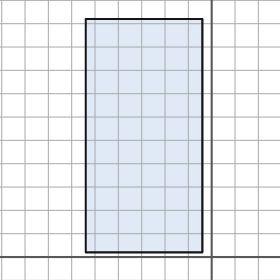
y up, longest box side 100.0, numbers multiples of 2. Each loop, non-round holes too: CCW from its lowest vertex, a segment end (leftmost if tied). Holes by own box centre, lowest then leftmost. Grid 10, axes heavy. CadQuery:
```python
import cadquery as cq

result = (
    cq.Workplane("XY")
    .moveTo(-54.0, 2.0)
    .lineTo(-4.0, 2.0)
    .lineTo(-4.0, 102.0)
    .lineTo(-54.0, 102.0)
    .close()
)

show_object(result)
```